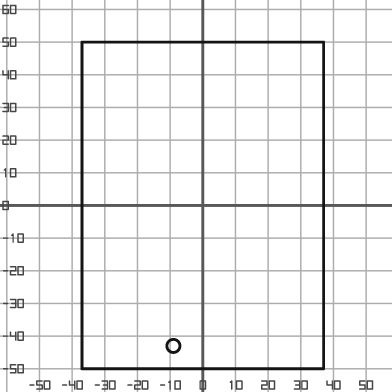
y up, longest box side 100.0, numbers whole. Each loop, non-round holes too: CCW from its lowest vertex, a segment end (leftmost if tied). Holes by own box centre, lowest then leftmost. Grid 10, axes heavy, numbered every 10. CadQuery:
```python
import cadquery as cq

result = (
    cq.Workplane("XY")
    .moveTo(-37.0, -50.0)
    .lineTo(37.0, -50.0)
    .lineTo(37.0, 50.0)
    .lineTo(-37.0, 50.0)
    .close()
    .moveTo(-9.0, -43.0)
    .circle(2.0)
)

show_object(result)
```